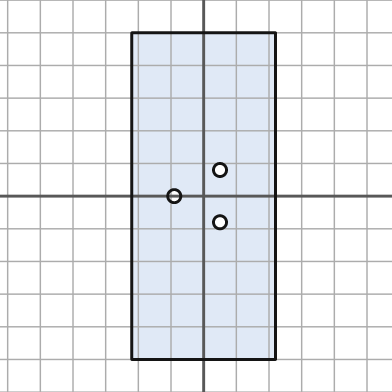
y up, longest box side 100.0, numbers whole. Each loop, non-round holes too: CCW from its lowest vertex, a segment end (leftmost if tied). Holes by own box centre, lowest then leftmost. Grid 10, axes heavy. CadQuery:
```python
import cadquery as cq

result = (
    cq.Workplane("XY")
    .moveTo(-22.0, -50.0)
    .lineTo(22.0, -50.0)
    .lineTo(22.0, 50.0)
    .lineTo(-22.0, 50.0)
    .close()
    .moveTo(5.0, -8.0)
    .circle(2.0)
    .moveTo(-9.0, 0.0)
    .circle(2.0)
    .moveTo(5.0, 8.0)
    .circle(2.0)
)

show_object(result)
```